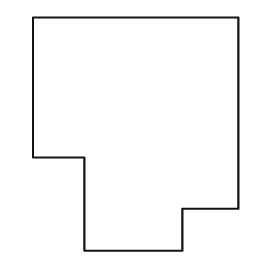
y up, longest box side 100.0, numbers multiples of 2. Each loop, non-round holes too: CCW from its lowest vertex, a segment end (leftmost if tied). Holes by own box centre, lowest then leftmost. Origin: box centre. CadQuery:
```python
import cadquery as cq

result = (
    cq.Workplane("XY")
    .moveTo(-22.0, -50.0)
    .lineTo(20.0, -50.0)
    .lineTo(20.0, -32.0)
    .lineTo(44.0, -32.0)
    .lineTo(44.0, 50.0)
    .lineTo(-44.0, 50.0)
    .lineTo(-44.0, -10.0)
    .lineTo(-22.0, -10.0)
    .close()
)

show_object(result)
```